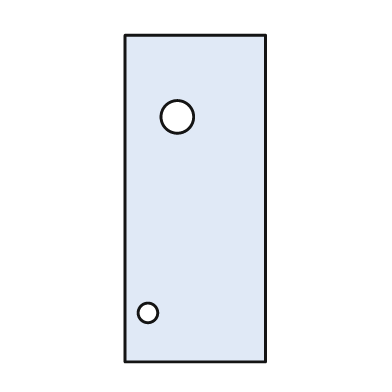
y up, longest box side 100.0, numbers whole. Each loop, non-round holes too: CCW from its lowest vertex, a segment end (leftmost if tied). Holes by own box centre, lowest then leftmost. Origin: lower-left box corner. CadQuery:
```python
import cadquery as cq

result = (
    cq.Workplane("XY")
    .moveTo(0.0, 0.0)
    .lineTo(43.0, 0.0)
    .lineTo(43.0, 100.0)
    .lineTo(0.0, 100.0)
    .close()
    .moveTo(7.0, 15.0)
    .circle(3.0)
    .moveTo(16.0, 75.0)
    .circle(5.0)
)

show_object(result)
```